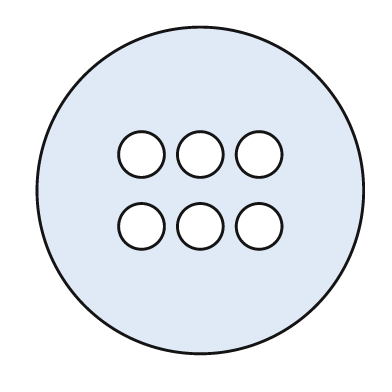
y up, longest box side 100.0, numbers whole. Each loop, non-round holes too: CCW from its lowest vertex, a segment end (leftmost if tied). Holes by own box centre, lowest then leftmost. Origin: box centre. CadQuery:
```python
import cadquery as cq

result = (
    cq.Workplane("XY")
    .moveTo(0.0, 0.0)
    .circle(50.0)
    .moveTo(-18.0, -11.0)
    .circle(7.0)
    .moveTo(0.0, -11.0)
    .circle(7.0)
    .moveTo(18.0, -11.0)
    .circle(7.0)
    .moveTo(-18.0, 11.0)
    .circle(7.0)
    .moveTo(0.0, 11.0)
    .circle(7.0)
    .moveTo(18.0, 11.0)
    .circle(7.0)
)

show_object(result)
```